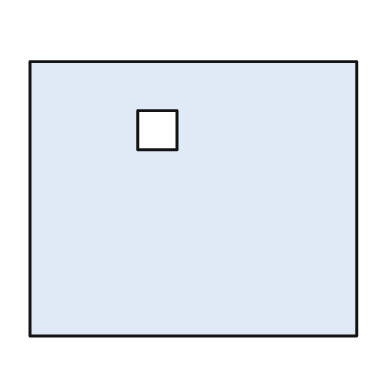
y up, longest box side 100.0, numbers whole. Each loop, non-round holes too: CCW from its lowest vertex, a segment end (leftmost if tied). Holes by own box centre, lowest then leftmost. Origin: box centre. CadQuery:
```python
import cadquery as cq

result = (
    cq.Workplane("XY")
    .moveTo(-50.0, -42.0)
    .lineTo(50.0, -42.0)
    .lineTo(50.0, 42.0)
    .lineTo(-50.0, 42.0)
    .close()
    .moveTo(-17.0, 15.0)
    .lineTo(-5.0, 15.0)
    .lineTo(-5.0, 27.0)
    .lineTo(-17.0, 27.0)
    .close()
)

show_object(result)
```